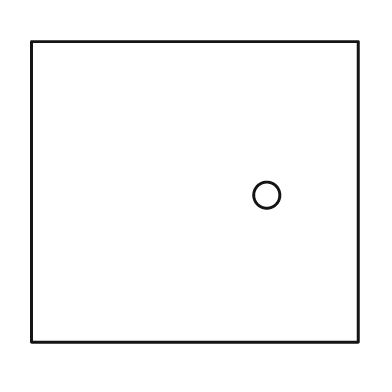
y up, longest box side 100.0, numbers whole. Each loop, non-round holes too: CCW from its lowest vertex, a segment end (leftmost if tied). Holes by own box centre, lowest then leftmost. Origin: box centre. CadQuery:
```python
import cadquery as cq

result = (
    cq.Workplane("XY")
    .moveTo(-50.0, -46.0)
    .lineTo(50.0, -46.0)
    .lineTo(50.0, 46.0)
    .lineTo(-50.0, 46.0)
    .close()
    .moveTo(22.0, -1.0)
    .circle(4.0)
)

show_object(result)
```